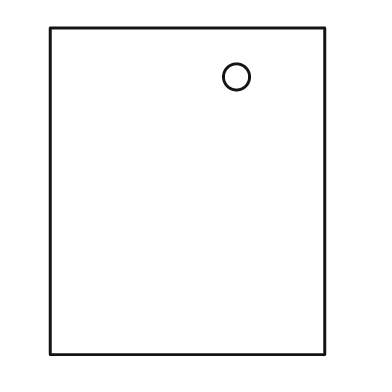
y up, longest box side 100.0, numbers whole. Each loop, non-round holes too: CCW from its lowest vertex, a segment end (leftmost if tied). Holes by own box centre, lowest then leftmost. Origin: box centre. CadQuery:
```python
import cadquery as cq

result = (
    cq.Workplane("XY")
    .moveTo(-42.0, -50.0)
    .lineTo(42.0, -50.0)
    .lineTo(42.0, 50.0)
    .lineTo(-42.0, 50.0)
    .close()
    .moveTo(15.0, 35.0)
    .circle(4.0)
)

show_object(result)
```